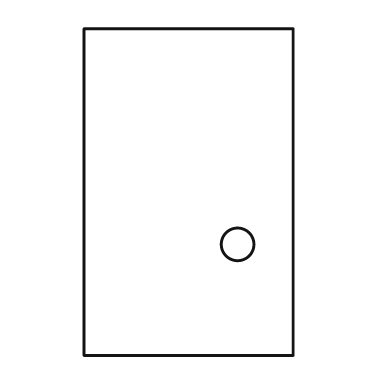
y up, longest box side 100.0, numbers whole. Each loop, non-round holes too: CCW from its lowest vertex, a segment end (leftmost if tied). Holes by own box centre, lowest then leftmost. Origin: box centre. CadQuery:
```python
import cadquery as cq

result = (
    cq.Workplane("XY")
    .moveTo(-32.0, -50.0)
    .lineTo(32.0, -50.0)
    .lineTo(32.0, 50.0)
    .lineTo(-32.0, 50.0)
    .close()
    .moveTo(15.0, -16.0)
    .circle(5.0)
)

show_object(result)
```